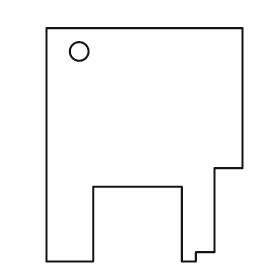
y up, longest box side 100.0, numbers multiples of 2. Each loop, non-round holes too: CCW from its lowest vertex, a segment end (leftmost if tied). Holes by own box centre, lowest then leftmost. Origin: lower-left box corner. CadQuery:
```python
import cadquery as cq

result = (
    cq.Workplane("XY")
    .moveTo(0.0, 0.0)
    .lineTo(20.0, 0.0)
    .lineTo(20.0, 32.0)
    .lineTo(58.0, 32.0)
    .lineTo(58.0, 0.0)
    .lineTo(64.0, 0.0)
    .lineTo(64.0, 4.0)
    .lineTo(72.0, 4.0)
    .lineTo(72.0, 40.0)
    .lineTo(84.0, 40.0)
    .lineTo(84.0, 100.0)
    .lineTo(0.0, 100.0)
    .close()
    .moveTo(14.0, 90.0)
    .circle(4.0)
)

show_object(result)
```